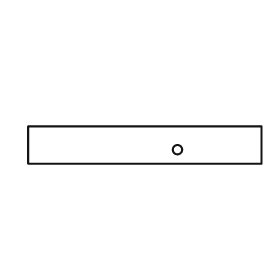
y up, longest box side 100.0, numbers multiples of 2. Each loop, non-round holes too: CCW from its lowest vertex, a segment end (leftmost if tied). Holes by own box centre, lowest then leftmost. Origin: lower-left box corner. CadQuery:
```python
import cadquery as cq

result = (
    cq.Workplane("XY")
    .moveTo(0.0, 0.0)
    .lineTo(100.0, 0.0)
    .lineTo(100.0, 16.0)
    .lineTo(0.0, 16.0)
    .close()
    .moveTo(64.0, 6.0)
    .circle(2.0)
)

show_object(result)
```